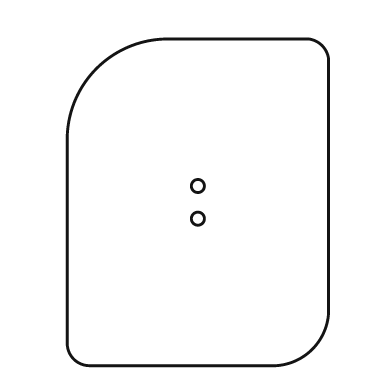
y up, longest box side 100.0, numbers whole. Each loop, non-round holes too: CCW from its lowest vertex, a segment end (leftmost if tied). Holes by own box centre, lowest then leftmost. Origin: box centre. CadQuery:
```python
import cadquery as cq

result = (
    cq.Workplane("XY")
    .moveTo(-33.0, -50.0)
    .lineTo(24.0, -50.0)
    .threePointArc((35.0, -45.0), (40.0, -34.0))
    .lineTo(40.0, 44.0)
    .threePointArc((38.0, 48.0), (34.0, 50.0))
    .lineTo(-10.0, 50.0)
    .threePointArc((-31.0, 41.0), (-40.0, 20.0))
    .lineTo(-40.0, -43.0)
    .threePointArc((-38.0, -48.0), (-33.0, -50.0))
    .close()
    .moveTo(0.0, -5.0)
    .circle(2.0)
    .moveTo(0.0, 5.0)
    .circle(2.0)
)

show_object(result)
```